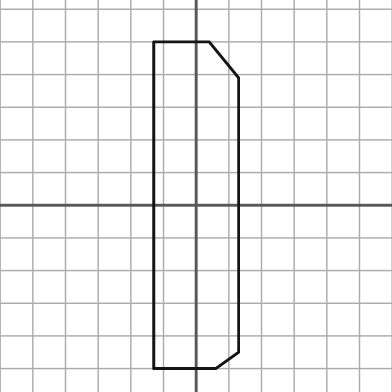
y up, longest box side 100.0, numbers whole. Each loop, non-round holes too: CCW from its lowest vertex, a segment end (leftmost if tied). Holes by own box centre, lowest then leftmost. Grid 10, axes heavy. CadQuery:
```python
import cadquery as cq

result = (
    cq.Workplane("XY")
    .moveTo(-13.0, -50.0)
    .lineTo(6.0, -50.0)
    .lineTo(13.0, -45.0)
    .lineTo(13.0, 39.0)
    .lineTo(4.0, 50.0)
    .lineTo(-13.0, 50.0)
    .close()
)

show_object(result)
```